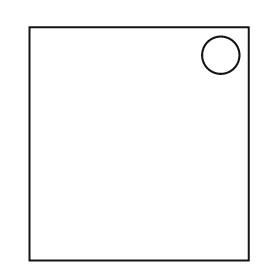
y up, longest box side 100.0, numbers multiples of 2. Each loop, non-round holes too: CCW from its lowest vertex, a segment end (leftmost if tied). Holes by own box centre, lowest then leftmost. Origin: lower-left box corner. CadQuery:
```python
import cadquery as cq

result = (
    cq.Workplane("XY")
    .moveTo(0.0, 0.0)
    .lineTo(94.0, 0.0)
    .lineTo(94.0, 100.0)
    .lineTo(0.0, 100.0)
    .close()
    .moveTo(82.0, 88.0)
    .circle(8.0)
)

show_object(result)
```